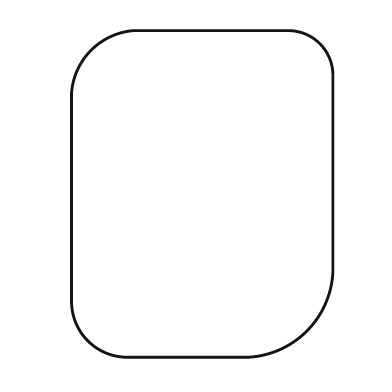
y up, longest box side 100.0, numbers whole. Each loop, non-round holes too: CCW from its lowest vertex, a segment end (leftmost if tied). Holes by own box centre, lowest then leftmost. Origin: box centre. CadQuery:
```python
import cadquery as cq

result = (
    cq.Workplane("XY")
    .moveTo(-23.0, -50.0)
    .lineTo(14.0, -50.0)
    .threePointArc((32.0, -42.0), (40.0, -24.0))
    .lineTo(40.0, 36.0)
    .threePointArc((36.0, 46.0), (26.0, 50.0))
    .lineTo(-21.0, 50.0)
    .threePointArc((-34.0, 44.0), (-40.0, 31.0))
    .lineTo(-40.0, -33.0)
    .threePointArc((-35.0, -45.0), (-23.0, -50.0))
    .close()
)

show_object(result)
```